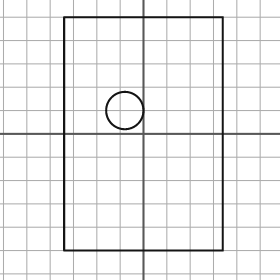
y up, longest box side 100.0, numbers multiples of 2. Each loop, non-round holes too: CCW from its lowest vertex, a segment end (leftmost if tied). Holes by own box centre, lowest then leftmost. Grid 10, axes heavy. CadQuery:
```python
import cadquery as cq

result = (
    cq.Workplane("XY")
    .moveTo(-34.0, -50.0)
    .lineTo(34.0, -50.0)
    .lineTo(34.0, 50.0)
    .lineTo(-34.0, 50.0)
    .close()
    .moveTo(-8.0, 10.0)
    .circle(8.0)
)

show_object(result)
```